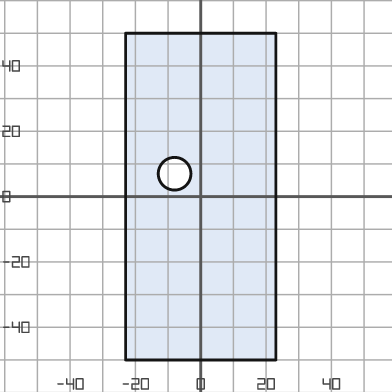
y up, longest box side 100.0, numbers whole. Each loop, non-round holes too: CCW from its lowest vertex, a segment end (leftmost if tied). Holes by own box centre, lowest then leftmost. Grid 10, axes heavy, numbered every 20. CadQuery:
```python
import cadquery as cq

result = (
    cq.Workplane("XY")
    .moveTo(-23.0, -50.0)
    .lineTo(23.0, -50.0)
    .lineTo(23.0, 50.0)
    .lineTo(-23.0, 50.0)
    .close()
    .moveTo(-8.0, 7.0)
    .circle(5.0)
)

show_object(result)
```